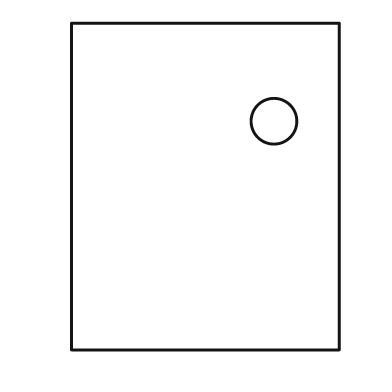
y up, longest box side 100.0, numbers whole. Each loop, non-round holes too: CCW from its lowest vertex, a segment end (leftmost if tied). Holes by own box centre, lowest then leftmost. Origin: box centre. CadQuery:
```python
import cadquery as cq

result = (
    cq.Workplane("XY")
    .moveTo(-41.0, -50.0)
    .lineTo(41.0, -50.0)
    .lineTo(41.0, 50.0)
    .lineTo(-41.0, 50.0)
    .close()
    .moveTo(21.0, 20.0)
    .circle(7.0)
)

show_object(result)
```